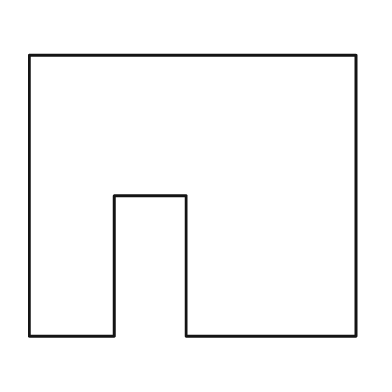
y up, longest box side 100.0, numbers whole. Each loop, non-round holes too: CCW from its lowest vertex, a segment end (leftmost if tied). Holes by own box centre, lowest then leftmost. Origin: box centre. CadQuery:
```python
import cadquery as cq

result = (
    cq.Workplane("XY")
    .moveTo(-50.0, -43.0)
    .lineTo(-24.0, -43.0)
    .lineTo(-24.0, 0.0)
    .lineTo(-2.0, 0.0)
    .lineTo(-2.0, -43.0)
    .lineTo(50.0, -43.0)
    .lineTo(50.0, 43.0)
    .lineTo(-50.0, 43.0)
    .close()
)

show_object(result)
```